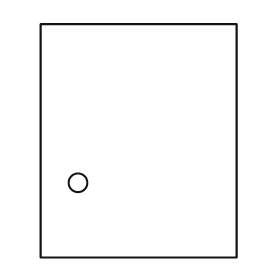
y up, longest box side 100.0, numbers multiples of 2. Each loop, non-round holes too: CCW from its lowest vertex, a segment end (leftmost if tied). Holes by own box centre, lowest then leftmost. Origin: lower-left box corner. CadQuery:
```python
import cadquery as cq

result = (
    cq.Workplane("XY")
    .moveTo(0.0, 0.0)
    .lineTo(84.0, 0.0)
    .lineTo(84.0, 100.0)
    .lineTo(0.0, 100.0)
    .close()
    .moveTo(16.0, 32.0)
    .circle(4.0)
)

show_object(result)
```